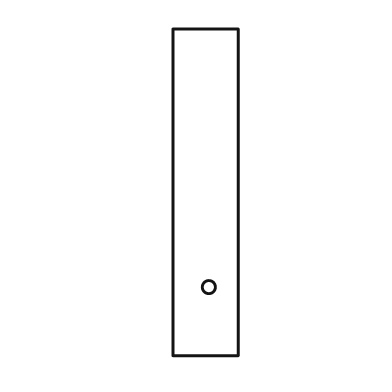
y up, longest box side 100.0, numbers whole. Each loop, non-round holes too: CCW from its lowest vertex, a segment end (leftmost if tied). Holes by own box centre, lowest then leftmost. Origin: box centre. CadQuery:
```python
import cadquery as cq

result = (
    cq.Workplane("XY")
    .moveTo(-10.0, -50.0)
    .lineTo(10.0, -50.0)
    .lineTo(10.0, 50.0)
    .lineTo(-10.0, 50.0)
    .close()
    .moveTo(1.0, -29.0)
    .circle(2.0)
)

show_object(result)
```